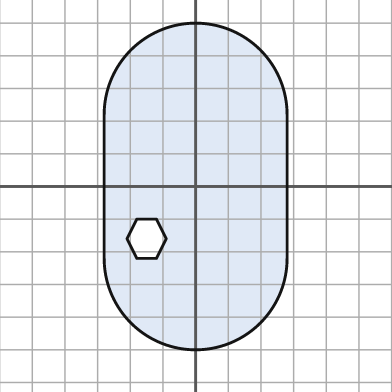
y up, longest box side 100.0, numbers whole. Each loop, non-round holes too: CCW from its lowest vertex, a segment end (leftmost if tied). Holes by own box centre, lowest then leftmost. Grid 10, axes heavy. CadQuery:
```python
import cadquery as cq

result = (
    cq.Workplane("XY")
    .moveTo(-28.0, -22.0)
    .threePointArc((0.0, -50.0), (28.0, -22.0))
    .lineTo(28.0, 22.0)
    .threePointArc((0.0, 50.0), (-28.0, 22.0))
    .close()
    .moveTo(-18.0, -22.0)
    .lineTo(-12.0, -22.0)
    .lineTo(-9.0, -16.0)
    .lineTo(-12.0, -10.0)
    .lineTo(-18.0, -10.0)
    .lineTo(-21.0, -16.0)
    .close()
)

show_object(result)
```